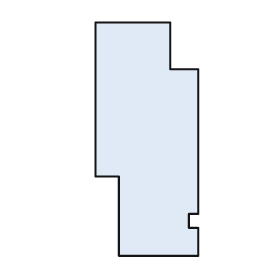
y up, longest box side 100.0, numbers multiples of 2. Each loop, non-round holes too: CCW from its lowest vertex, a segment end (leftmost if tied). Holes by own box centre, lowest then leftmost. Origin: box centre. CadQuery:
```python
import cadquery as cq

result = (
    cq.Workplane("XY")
    .moveTo(-12.0, -50.0)
    .lineTo(22.0, -50.0)
    .lineTo(22.0, -38.0)
    .lineTo(18.0, -38.0)
    .lineTo(18.0, -32.0)
    .lineTo(22.0, -32.0)
    .lineTo(22.0, 30.0)
    .lineTo(10.0, 30.0)
    .lineTo(10.0, 50.0)
    .lineTo(-22.0, 50.0)
    .lineTo(-22.0, -16.0)
    .lineTo(-12.0, -16.0)
    .close()
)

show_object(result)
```